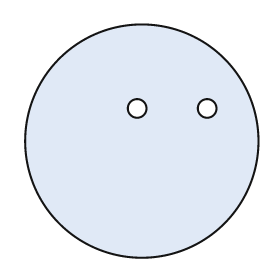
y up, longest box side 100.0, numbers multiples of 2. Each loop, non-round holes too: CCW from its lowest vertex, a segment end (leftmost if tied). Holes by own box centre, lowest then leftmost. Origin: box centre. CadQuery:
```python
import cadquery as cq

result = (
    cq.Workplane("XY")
    .moveTo(0.0, 0.0)
    .circle(50.0)
    .moveTo(-2.0, 14.0)
    .circle(4.0)
    .moveTo(28.0, 14.0)
    .circle(4.0)
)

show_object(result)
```